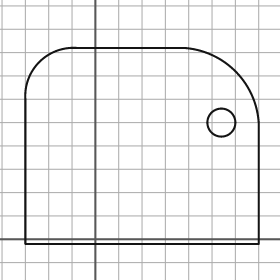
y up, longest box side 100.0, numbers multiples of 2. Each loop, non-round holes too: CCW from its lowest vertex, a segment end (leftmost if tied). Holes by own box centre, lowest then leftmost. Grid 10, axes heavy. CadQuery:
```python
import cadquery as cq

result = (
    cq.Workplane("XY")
    .moveTo(-30.0, -2.0)
    .lineTo(70.0, -2.0)
    .lineTo(70.0, 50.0)
    .threePointArc((60.0, 72.0), (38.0, 82.0))
    .lineTo(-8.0, 82.0)
    .threePointArc((-24.0, 76.0), (-30.0, 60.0))
    .close()
    .moveTo(54.0, 50.0)
    .circle(6.0)
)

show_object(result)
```